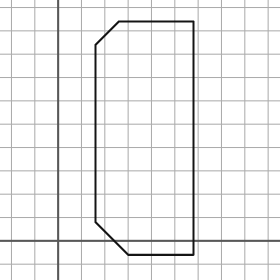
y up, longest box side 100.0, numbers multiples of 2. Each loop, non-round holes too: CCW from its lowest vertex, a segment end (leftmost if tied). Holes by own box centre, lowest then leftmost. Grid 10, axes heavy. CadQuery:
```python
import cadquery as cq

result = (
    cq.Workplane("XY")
    .moveTo(30.0, -6.0)
    .lineTo(58.0, -6.0)
    .lineTo(58.0, 94.0)
    .lineTo(26.0, 94.0)
    .lineTo(16.0, 84.0)
    .lineTo(16.0, 8.0)
    .close()
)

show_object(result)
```